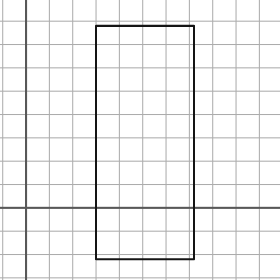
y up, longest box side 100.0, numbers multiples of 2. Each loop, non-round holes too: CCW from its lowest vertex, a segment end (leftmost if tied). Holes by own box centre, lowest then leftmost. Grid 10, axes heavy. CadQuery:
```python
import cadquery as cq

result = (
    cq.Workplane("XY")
    .moveTo(30.0, -22.0)
    .lineTo(72.0, -22.0)
    .lineTo(72.0, 78.0)
    .lineTo(30.0, 78.0)
    .close()
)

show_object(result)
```